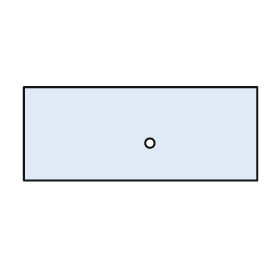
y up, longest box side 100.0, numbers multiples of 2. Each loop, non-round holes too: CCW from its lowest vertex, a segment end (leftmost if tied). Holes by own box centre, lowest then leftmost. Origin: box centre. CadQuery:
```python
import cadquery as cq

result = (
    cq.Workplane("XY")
    .moveTo(-50.0, -20.0)
    .lineTo(50.0, -20.0)
    .lineTo(50.0, 20.0)
    .lineTo(-50.0, 20.0)
    .close()
    .moveTo(4.0, -4.0)
    .circle(2.0)
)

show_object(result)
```